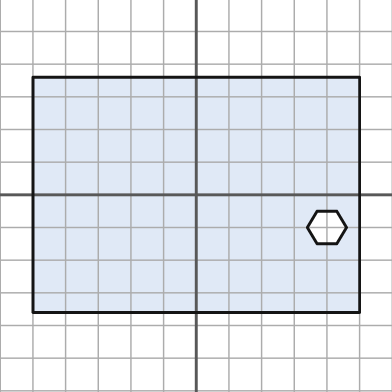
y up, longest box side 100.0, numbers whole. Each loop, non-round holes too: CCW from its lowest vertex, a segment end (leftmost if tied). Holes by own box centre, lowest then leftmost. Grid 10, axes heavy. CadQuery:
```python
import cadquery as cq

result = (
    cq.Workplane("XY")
    .moveTo(-50.0, -36.0)
    .lineTo(50.0, -36.0)
    .lineTo(50.0, 36.0)
    .lineTo(-50.0, 36.0)
    .close()
    .moveTo(37.0, -15.0)
    .lineTo(43.0, -15.0)
    .lineTo(46.0, -10.0)
    .lineTo(43.0, -5.0)
    .lineTo(37.0, -5.0)
    .lineTo(34.0, -10.0)
    .close()
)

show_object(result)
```